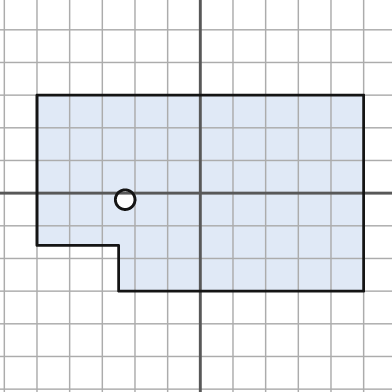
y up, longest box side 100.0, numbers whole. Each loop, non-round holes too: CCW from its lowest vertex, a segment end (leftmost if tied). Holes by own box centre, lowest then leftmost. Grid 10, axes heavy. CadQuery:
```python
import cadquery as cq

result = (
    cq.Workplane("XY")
    .moveTo(-25.0, -30.0)
    .lineTo(50.0, -30.0)
    .lineTo(50.0, 30.0)
    .lineTo(-50.0, 30.0)
    .lineTo(-50.0, -16.0)
    .lineTo(-25.0, -16.0)
    .close()
    .moveTo(-23.0, -2.0)
    .circle(3.0)
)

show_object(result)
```